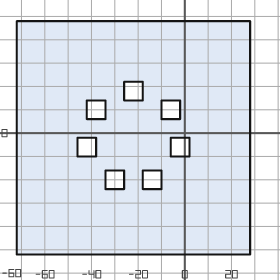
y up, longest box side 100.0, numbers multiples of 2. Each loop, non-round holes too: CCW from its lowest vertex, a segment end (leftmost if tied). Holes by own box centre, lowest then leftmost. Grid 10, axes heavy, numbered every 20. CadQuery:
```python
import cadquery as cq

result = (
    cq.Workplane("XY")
    .moveTo(-72.0, -52.0)
    .lineTo(28.0, -52.0)
    .lineTo(28.0, 48.0)
    .lineTo(-72.0, 48.0)
    .close()
    .moveTo(-34.0, -24.0)
    .lineTo(-26.0, -24.0)
    .lineTo(-26.0, -16.0)
    .lineTo(-34.0, -16.0)
    .close()
    .moveTo(-18.0, -24.0)
    .lineTo(-10.0, -24.0)
    .lineTo(-10.0, -16.0)
    .lineTo(-18.0, -16.0)
    .close()
    .moveTo(-46.0, -10.0)
    .lineTo(-38.0, -10.0)
    .lineTo(-38.0, -2.0)
    .lineTo(-46.0, -2.0)
    .close()
    .moveTo(-6.0, -10.0)
    .lineTo(2.0, -10.0)
    .lineTo(2.0, -2.0)
    .lineTo(-6.0, -2.0)
    .close()
    .moveTo(-42.0, 6.0)
    .lineTo(-34.0, 6.0)
    .lineTo(-34.0, 14.0)
    .lineTo(-42.0, 14.0)
    .close()
    .moveTo(-10.0, 6.0)
    .lineTo(-2.0, 6.0)
    .lineTo(-2.0, 14.0)
    .lineTo(-10.0, 14.0)
    .close()
    .moveTo(-26.0, 14.0)
    .lineTo(-18.0, 14.0)
    .lineTo(-18.0, 22.0)
    .lineTo(-26.0, 22.0)
    .close()
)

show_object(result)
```